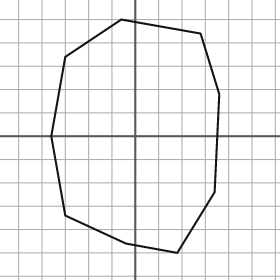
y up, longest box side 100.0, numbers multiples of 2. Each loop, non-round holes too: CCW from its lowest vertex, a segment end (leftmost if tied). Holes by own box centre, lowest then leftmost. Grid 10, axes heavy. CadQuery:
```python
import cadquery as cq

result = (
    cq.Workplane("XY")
    .moveTo(18.0, -50.0)
    .lineTo(34.0, -24.0)
    .lineTo(36.0, 18.0)
    .lineTo(28.0, 44.0)
    .lineTo(-6.0, 50.0)
    .lineTo(-30.0, 34.0)
    .lineTo(-36.0, 0.0)
    .lineTo(-30.0, -34.0)
    .lineTo(-4.0, -46.0)
    .close()
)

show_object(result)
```